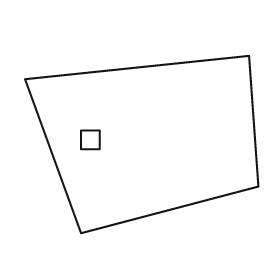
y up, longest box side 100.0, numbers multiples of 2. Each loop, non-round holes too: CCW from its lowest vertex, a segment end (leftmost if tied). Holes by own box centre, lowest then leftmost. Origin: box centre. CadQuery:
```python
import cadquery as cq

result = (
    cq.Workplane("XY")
    .moveTo(-26.0, -38.0)
    .lineTo(50.0, -18.0)
    .lineTo(46.0, 38.0)
    .lineTo(-50.0, 28.0)
    .close()
    .moveTo(-26.0, -2.0)
    .lineTo(-18.0, -2.0)
    .lineTo(-18.0, 6.0)
    .lineTo(-26.0, 6.0)
    .close()
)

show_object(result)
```